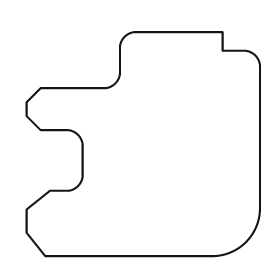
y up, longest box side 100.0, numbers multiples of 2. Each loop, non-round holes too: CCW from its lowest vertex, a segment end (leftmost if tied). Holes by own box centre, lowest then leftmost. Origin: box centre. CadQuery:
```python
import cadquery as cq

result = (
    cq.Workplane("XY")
    .moveTo(-42.0, -48.0)
    .lineTo(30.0, -48.0)
    .threePointArc((44.0, -42.0), (50.0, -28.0))
    .lineTo(50.0, 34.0)
    .threePointArc((48.0, 38.0), (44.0, 40.0))
    .lineTo(34.0, 40.0)
    .lineTo(34.0, 48.0)
    .lineTo(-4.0, 48.0)
    .threePointArc((-8.0, 46.0), (-10.0, 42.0))
    .lineTo(-10.0, 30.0)
    .threePointArc((-12.0, 26.0), (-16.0, 24.0))
    .lineTo(-44.0, 24.0)
    .lineTo(-50.0, 18.0)
    .lineTo(-50.0, 12.0)
    .lineTo(-44.0, 6.0)
    .lineTo(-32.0, 6.0)
    .threePointArc((-28.0, 4.0), (-26.0, 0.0))
    .lineTo(-26.0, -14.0)
    .threePointArc((-28.0, -18.0), (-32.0, -20.0))
    .lineTo(-40.0, -20.0)
    .lineTo(-50.0, -28.0)
    .lineTo(-50.0, -38.0)
    .close()
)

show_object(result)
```